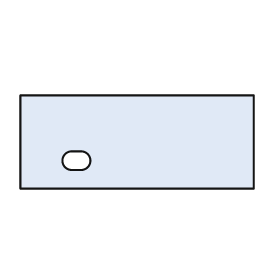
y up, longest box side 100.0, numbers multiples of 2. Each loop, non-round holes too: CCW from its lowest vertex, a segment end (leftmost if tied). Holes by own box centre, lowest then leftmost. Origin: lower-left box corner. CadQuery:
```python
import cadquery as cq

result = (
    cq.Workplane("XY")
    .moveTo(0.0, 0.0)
    .lineTo(100.0, 0.0)
    .lineTo(100.0, 40.0)
    .lineTo(0.0, 40.0)
    .close()
    .moveTo(22.0, 8.0)
    .lineTo(26.0, 8.0)
    .threePointArc((30.0, 12.0), (26.0, 16.0))
    .lineTo(22.0, 16.0)
    .threePointArc((18.0, 12.0), (22.0, 8.0))
    .close()
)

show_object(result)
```